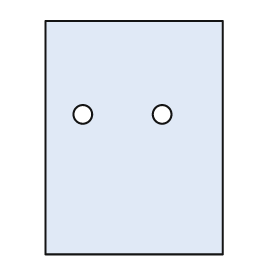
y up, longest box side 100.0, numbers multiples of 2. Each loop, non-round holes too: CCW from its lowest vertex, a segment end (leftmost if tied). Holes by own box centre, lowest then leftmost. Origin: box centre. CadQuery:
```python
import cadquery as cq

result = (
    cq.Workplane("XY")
    .moveTo(-38.0, -50.0)
    .lineTo(38.0, -50.0)
    .lineTo(38.0, 50.0)
    .lineTo(-38.0, 50.0)
    .close()
    .moveTo(-22.0, 10.0)
    .circle(4.0)
    .moveTo(12.0, 10.0)
    .circle(4.0)
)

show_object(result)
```